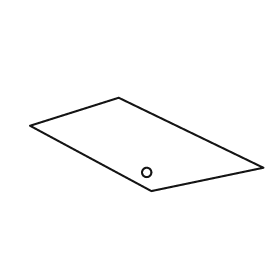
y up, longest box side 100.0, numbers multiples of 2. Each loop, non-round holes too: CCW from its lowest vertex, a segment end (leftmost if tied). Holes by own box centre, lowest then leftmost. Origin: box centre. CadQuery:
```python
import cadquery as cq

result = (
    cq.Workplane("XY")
    .moveTo(2.0, -20.0)
    .lineTo(50.0, -10.0)
    .lineTo(-12.0, 20.0)
    .lineTo(-50.0, 8.0)
    .close()
    .moveTo(0.0, -12.0)
    .circle(2.0)
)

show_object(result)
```